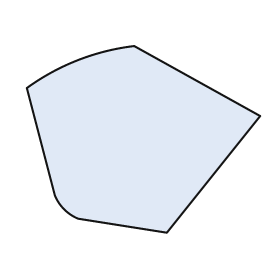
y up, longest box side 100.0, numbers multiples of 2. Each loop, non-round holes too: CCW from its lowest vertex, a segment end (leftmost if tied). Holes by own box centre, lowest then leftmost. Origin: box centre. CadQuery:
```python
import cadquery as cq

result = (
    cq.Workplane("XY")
    .moveTo(10.0, -40.0)
    .lineTo(50.0, 10.0)
    .lineTo(-4.0, 40.0)
    .threePointArc((-28.0, 34.0), (-50.0, 22.0))
    .lineTo(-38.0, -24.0)
    .threePointArc((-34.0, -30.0), (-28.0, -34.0))
    .close()
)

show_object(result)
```